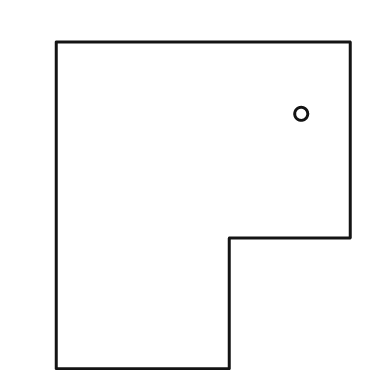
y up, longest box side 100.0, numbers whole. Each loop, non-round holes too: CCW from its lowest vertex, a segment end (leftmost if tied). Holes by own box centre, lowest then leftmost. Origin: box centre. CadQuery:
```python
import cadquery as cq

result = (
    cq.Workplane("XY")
    .moveTo(-45.0, -50.0)
    .lineTo(8.0, -50.0)
    .lineTo(8.0, -10.0)
    .lineTo(45.0, -10.0)
    .lineTo(45.0, 50.0)
    .lineTo(-45.0, 50.0)
    .close()
    .moveTo(30.0, 28.0)
    .circle(2.0)
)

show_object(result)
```